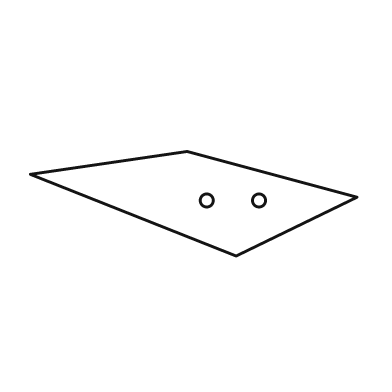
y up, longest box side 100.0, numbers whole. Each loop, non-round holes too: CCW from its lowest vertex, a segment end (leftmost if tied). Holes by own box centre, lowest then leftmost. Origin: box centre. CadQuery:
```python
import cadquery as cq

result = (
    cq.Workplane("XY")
    .moveTo(13.0, -16.0)
    .lineTo(50.0, 2.0)
    .lineTo(-2.0, 16.0)
    .lineTo(-50.0, 9.0)
    .close()
    .moveTo(4.0, 1.0)
    .circle(2.0)
    .moveTo(20.0, 1.0)
    .circle(2.0)
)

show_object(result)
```